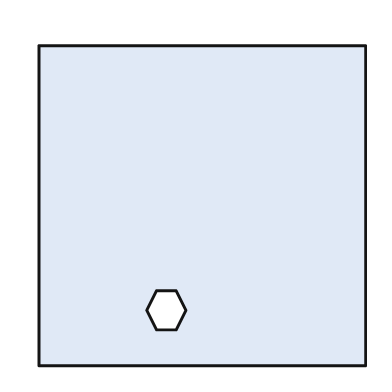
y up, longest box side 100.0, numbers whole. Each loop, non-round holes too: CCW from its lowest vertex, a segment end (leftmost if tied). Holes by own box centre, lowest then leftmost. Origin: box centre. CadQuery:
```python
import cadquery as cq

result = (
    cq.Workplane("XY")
    .moveTo(-50.0, -49.0)
    .lineTo(50.0, -49.0)
    .lineTo(50.0, 49.0)
    .lineTo(-50.0, 49.0)
    .close()
    .moveTo(-14.0, -38.0)
    .lineTo(-8.0, -38.0)
    .lineTo(-5.0, -32.0)
    .lineTo(-8.0, -26.0)
    .lineTo(-14.0, -26.0)
    .lineTo(-17.0, -32.0)
    .close()
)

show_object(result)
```